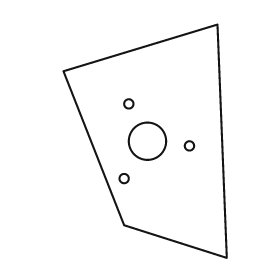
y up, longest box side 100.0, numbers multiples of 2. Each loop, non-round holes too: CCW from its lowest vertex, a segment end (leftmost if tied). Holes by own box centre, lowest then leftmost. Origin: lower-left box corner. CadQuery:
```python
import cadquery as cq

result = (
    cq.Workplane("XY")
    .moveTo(70.0, 0.0)
    .lineTo(66.0, 100.0)
    .lineTo(0.0, 80.0)
    .lineTo(26.0, 14.0)
    .close()
    .moveTo(26.0, 34.0)
    .circle(2.0)
    .moveTo(54.0, 48.0)
    .circle(2.0)
    .moveTo(36.0, 50.0)
    .circle(8.0)
    .moveTo(28.0, 66.0)
    .circle(2.0)
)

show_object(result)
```